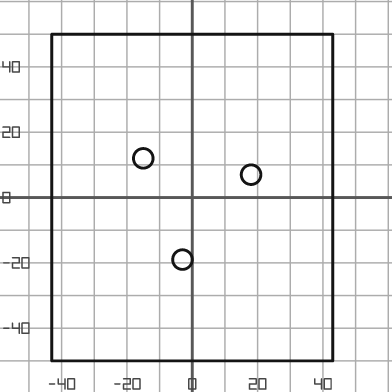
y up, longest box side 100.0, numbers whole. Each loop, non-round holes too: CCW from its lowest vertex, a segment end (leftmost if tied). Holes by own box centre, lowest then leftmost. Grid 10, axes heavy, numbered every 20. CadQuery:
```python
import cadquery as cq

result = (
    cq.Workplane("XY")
    .moveTo(-43.0, -50.0)
    .lineTo(43.0, -50.0)
    .lineTo(43.0, 50.0)
    .lineTo(-43.0, 50.0)
    .close()
    .moveTo(-3.0, -19.0)
    .circle(3.0)
    .moveTo(18.0, 7.0)
    .circle(3.0)
    .moveTo(-15.0, 12.0)
    .circle(3.0)
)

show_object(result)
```